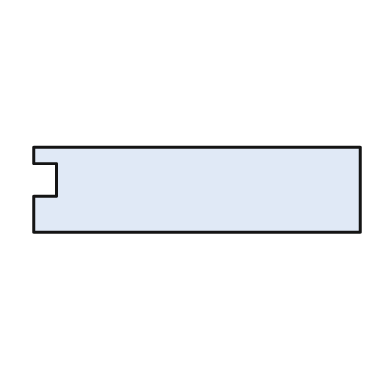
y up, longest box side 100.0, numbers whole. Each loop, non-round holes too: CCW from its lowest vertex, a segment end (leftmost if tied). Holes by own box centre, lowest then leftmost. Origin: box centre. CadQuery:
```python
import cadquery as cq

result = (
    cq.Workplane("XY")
    .moveTo(-50.0, -13.0)
    .lineTo(50.0, -13.0)
    .lineTo(50.0, 13.0)
    .lineTo(-50.0, 13.0)
    .lineTo(-50.0, 8.0)
    .lineTo(-43.0, 8.0)
    .lineTo(-43.0, -2.0)
    .lineTo(-50.0, -2.0)
    .close()
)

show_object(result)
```